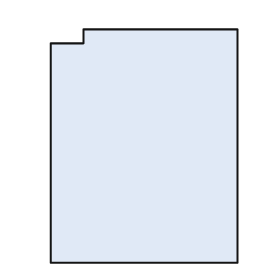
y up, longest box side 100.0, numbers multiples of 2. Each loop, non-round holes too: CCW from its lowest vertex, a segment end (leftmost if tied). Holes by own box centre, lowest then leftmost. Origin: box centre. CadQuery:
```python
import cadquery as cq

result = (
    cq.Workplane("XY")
    .moveTo(-40.0, -50.0)
    .lineTo(40.0, -50.0)
    .lineTo(40.0, 50.0)
    .lineTo(-26.0, 50.0)
    .lineTo(-26.0, 44.0)
    .lineTo(-40.0, 44.0)
    .close()
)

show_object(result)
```